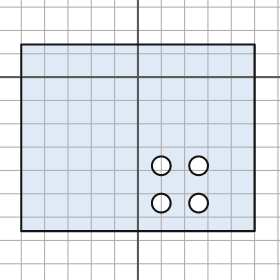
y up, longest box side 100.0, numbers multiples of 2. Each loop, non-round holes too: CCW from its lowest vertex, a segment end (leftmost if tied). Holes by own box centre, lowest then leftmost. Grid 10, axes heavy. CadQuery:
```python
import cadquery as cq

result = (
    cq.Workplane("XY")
    .moveTo(-50.0, -66.0)
    .lineTo(50.0, -66.0)
    .lineTo(50.0, 14.0)
    .lineTo(-50.0, 14.0)
    .close()
    .moveTo(10.0, -54.0)
    .circle(4.0)
    .moveTo(26.0, -54.0)
    .circle(4.0)
    .moveTo(10.0, -38.0)
    .circle(4.0)
    .moveTo(26.0, -38.0)
    .circle(4.0)
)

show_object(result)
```